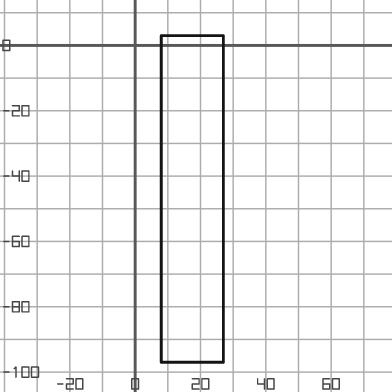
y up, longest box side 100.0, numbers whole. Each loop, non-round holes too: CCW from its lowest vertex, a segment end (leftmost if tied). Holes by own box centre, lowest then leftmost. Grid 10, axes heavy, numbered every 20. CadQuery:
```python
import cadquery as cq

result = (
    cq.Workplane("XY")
    .moveTo(8.0, -97.0)
    .lineTo(27.0, -97.0)
    .lineTo(27.0, 3.0)
    .lineTo(8.0, 3.0)
    .close()
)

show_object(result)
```